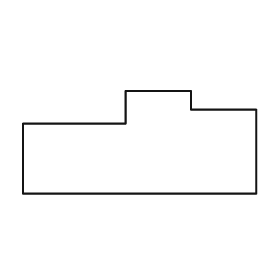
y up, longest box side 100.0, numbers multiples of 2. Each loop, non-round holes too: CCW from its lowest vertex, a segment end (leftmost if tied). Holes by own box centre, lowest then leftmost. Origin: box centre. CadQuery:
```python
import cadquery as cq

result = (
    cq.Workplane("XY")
    .moveTo(-50.0, -22.0)
    .lineTo(50.0, -22.0)
    .lineTo(50.0, 14.0)
    .lineTo(22.0, 14.0)
    .lineTo(22.0, 22.0)
    .lineTo(-6.0, 22.0)
    .lineTo(-6.0, 8.0)
    .lineTo(-50.0, 8.0)
    .close()
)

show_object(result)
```